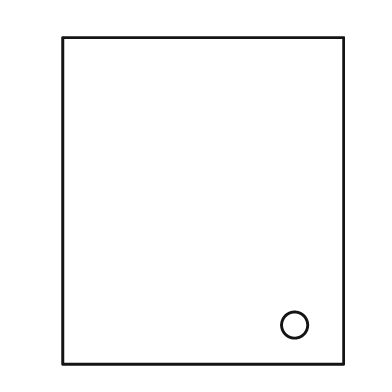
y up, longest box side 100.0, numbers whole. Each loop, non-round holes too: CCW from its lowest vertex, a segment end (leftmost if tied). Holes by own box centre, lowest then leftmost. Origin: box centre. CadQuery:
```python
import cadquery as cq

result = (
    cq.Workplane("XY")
    .moveTo(-43.0, -50.0)
    .lineTo(43.0, -50.0)
    .lineTo(43.0, 50.0)
    .lineTo(-43.0, 50.0)
    .close()
    .moveTo(28.0, -38.0)
    .circle(4.0)
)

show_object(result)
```